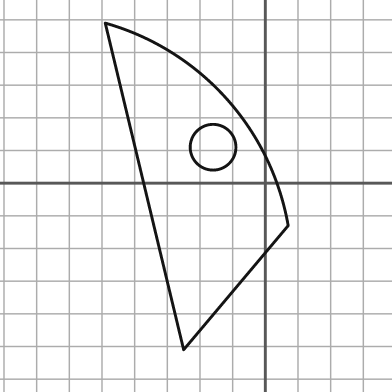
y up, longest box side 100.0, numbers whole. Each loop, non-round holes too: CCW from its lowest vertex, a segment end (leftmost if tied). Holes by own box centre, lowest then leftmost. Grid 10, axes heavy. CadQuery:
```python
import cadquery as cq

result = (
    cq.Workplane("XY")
    .moveTo(-25.0, -51.0)
    .lineTo(7.0, -13.0)
    .threePointArc((-12.0, 26.0), (-49.0, 49.0))
    .close()
    .moveTo(-16.0, 11.0)
    .circle(7.0)
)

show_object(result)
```